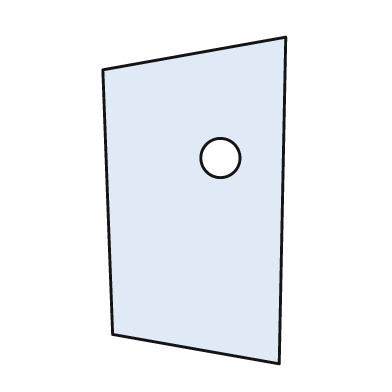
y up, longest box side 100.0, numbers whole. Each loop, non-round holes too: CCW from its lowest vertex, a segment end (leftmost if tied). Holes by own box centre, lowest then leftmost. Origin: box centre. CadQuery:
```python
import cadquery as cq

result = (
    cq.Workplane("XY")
    .moveTo(26.0, -50.0)
    .lineTo(28.0, 50.0)
    .lineTo(-28.0, 40.0)
    .lineTo(-25.0, -41.0)
    .close()
    .moveTo(8.0, 13.0)
    .circle(6.0)
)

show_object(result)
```